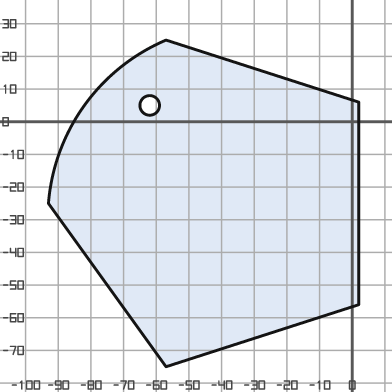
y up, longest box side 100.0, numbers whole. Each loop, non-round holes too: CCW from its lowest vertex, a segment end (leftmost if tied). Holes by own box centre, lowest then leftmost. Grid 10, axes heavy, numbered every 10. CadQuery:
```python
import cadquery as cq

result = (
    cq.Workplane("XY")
    .moveTo(-57.0, -75.0)
    .lineTo(2.0, -56.0)
    .lineTo(2.0, 6.0)
    .lineTo(-57.0, 25.0)
    .threePointArc((-82.0, 5.0), (-93.0, -25.0))
    .close()
    .moveTo(-62.0, 5.0)
    .circle(3.0)
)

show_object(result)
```